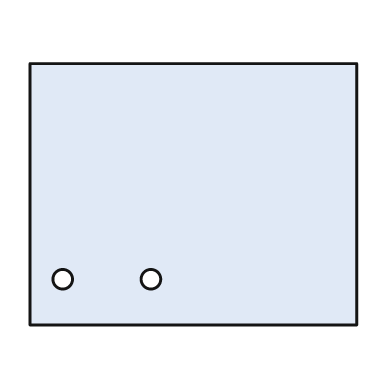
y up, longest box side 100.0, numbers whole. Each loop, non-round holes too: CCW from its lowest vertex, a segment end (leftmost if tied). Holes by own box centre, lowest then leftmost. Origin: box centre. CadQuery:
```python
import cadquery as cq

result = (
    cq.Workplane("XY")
    .moveTo(-50.0, -40.0)
    .lineTo(50.0, -40.0)
    .lineTo(50.0, 40.0)
    .lineTo(-50.0, 40.0)
    .close()
    .moveTo(-40.0, -26.0)
    .circle(3.0)
    .moveTo(-13.0, -26.0)
    .circle(3.0)
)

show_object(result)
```